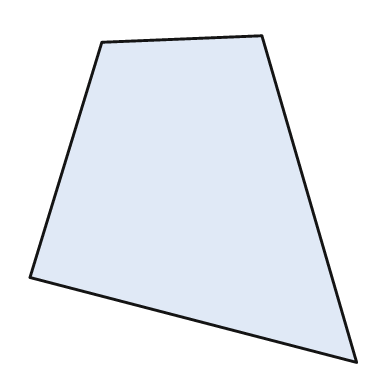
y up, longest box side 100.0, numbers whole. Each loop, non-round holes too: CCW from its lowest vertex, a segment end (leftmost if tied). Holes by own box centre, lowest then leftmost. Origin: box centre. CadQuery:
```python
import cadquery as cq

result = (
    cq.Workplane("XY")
    .moveTo(50.0, -50.0)
    .lineTo(21.0, 50.0)
    .lineTo(-28.0, 48.0)
    .lineTo(-50.0, -24.0)
    .close()
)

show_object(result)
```